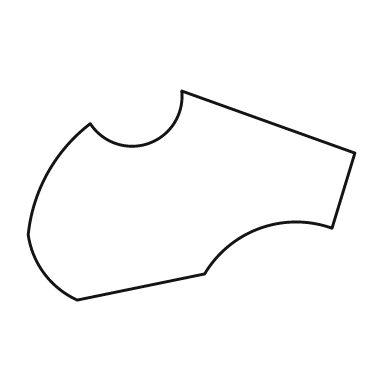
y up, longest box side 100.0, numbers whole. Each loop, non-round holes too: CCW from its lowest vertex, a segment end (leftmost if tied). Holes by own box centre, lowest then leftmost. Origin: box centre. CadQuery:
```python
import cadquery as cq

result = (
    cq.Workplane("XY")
    .moveTo(-35.0, -32.0)
    .lineTo(4.0, -24.0)
    .threePointArc((21.0, -10.0), (43.0, -10.0))
    .lineTo(50.0, 13.0)
    .lineTo(-3.0, 32.0)
    .threePointArc((-13.0, 16.0), (-31.0, 22.0))
    .threePointArc((-44.0, 7.0), (-50.0, -12.0))
    .threePointArc((-45.0, -24.0), (-35.0, -32.0))
    .close()
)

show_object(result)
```